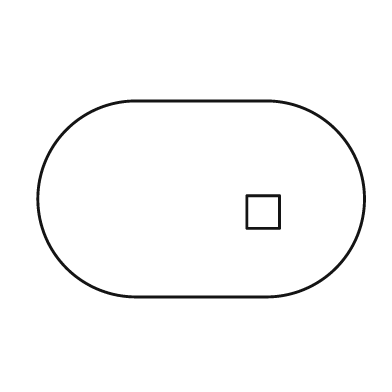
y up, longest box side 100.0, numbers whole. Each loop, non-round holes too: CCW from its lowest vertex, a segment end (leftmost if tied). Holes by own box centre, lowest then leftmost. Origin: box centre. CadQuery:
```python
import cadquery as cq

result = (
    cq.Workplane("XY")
    .moveTo(-20.0, -30.0)
    .lineTo(20.0, -30.0)
    .threePointArc((50.0, 0.0), (20.0, 30.0))
    .lineTo(-20.0, 30.0)
    .threePointArc((-50.0, 0.0), (-20.0, -30.0))
    .close()
    .moveTo(14.0, -9.0)
    .lineTo(24.0, -9.0)
    .lineTo(24.0, 1.0)
    .lineTo(14.0, 1.0)
    .close()
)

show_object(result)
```